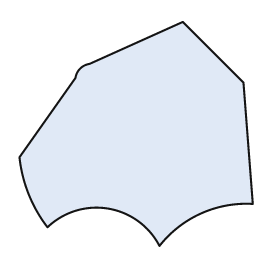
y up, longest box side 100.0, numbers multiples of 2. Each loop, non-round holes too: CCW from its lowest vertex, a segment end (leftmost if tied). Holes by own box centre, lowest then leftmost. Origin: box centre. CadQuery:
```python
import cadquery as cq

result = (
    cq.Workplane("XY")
    .moveTo(10.0, -48.0)
    .threePointArc((28.0, -34.0), (50.0, -30.0))
    .lineTo(46.0, 22.0)
    .lineTo(20.0, 48.0)
    .lineTo(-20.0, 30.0)
    .threePointArc((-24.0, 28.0), (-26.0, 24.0))
    .lineTo(-50.0, -10.0)
    .threePointArc((-46.0, -26.0), (-38.0, -40.0))
    .threePointArc((-12.0, -32.0), (10.0, -48.0))
    .close()
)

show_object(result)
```